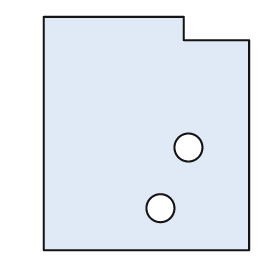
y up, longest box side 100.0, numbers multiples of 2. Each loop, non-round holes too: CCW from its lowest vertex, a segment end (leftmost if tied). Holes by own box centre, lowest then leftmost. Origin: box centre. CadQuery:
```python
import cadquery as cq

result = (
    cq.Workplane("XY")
    .moveTo(-44.0, -50.0)
    .lineTo(44.0, -50.0)
    .lineTo(44.0, 40.0)
    .lineTo(16.0, 40.0)
    .lineTo(16.0, 50.0)
    .lineTo(-44.0, 50.0)
    .close()
    .moveTo(6.0, -32.0)
    .circle(6.0)
    .moveTo(18.0, -6.0)
    .circle(6.0)
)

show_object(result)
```